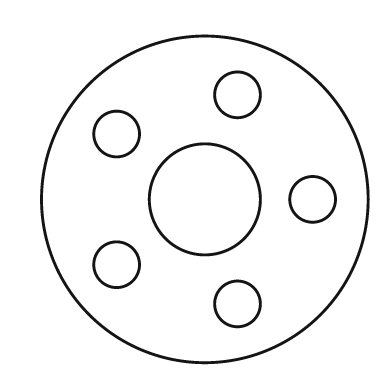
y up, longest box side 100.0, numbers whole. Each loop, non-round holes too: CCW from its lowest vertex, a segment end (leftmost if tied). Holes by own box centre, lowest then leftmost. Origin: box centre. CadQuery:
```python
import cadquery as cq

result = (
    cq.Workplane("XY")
    .moveTo(0.0, 0.0)
    .circle(50.0)
    .moveTo(10.0, -32.0)
    .circle(7.0)
    .moveTo(-27.0, -20.0)
    .circle(7.0)
    .moveTo(0.0, 0.0)
    .circle(17.0)
    .moveTo(33.0, 0.0)
    .circle(7.0)
    .moveTo(-27.0, 20.0)
    .circle(7.0)
    .moveTo(10.0, 32.0)
    .circle(7.0)
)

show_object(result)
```